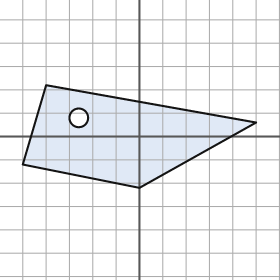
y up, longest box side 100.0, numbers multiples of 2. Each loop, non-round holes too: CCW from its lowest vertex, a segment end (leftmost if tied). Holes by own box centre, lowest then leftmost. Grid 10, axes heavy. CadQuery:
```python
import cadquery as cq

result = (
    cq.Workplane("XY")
    .moveTo(0.0, -22.0)
    .lineTo(50.0, 6.0)
    .lineTo(-40.0, 22.0)
    .lineTo(-50.0, -12.0)
    .close()
    .moveTo(-26.0, 8.0)
    .circle(4.0)
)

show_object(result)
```